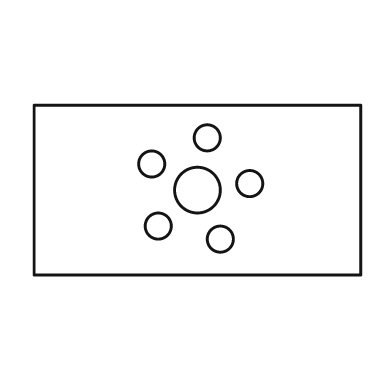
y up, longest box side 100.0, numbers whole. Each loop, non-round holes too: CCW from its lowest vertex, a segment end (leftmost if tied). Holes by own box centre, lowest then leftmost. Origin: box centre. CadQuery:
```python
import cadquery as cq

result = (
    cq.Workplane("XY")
    .moveTo(-50.0, -26.0)
    .lineTo(50.0, -26.0)
    .lineTo(50.0, 26.0)
    .lineTo(-50.0, 26.0)
    .close()
    .moveTo(7.0, -15.0)
    .circle(4.0)
    .moveTo(-12.0, -11.0)
    .circle(4.0)
    .moveTo(0.0, 0.0)
    .circle(7.0)
    .moveTo(16.0, 2.0)
    .circle(4.0)
    .moveTo(-14.0, 8.0)
    .circle(4.0)
    .moveTo(3.0, 16.0)
    .circle(4.0)
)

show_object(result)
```